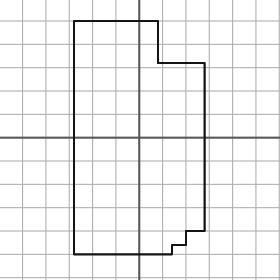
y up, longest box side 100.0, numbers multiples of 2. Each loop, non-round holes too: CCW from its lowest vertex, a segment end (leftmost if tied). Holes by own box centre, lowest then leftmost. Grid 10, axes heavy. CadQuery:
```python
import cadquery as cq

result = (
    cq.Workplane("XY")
    .moveTo(-28.0, -50.0)
    .lineTo(14.0, -50.0)
    .lineTo(14.0, -46.0)
    .lineTo(20.0, -46.0)
    .lineTo(20.0, -40.0)
    .lineTo(28.0, -40.0)
    .lineTo(28.0, 32.0)
    .lineTo(8.0, 32.0)
    .lineTo(8.0, 50.0)
    .lineTo(-28.0, 50.0)
    .close()
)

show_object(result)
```